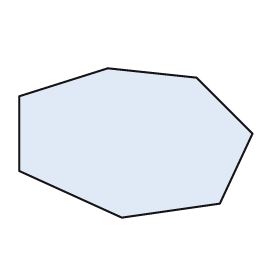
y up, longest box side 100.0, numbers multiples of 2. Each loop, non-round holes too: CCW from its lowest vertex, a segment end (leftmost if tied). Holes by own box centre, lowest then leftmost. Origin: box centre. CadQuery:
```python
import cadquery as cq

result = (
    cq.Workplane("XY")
    .moveTo(-6.0, -32.0)
    .lineTo(36.0, -26.0)
    .lineTo(50.0, 4.0)
    .lineTo(26.0, 28.0)
    .lineTo(-12.0, 32.0)
    .lineTo(-50.0, 20.0)
    .lineTo(-50.0, -12.0)
    .close()
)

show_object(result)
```